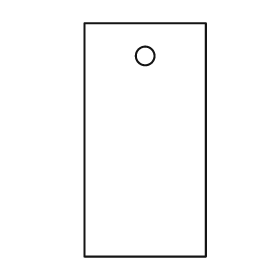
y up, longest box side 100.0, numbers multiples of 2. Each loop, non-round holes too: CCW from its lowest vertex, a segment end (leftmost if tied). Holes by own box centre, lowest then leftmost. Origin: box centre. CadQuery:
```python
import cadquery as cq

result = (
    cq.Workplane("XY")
    .moveTo(-26.0, -50.0)
    .lineTo(26.0, -50.0)
    .lineTo(26.0, 50.0)
    .lineTo(-26.0, 50.0)
    .close()
    .moveTo(0.0, 36.0)
    .circle(4.0)
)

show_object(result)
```